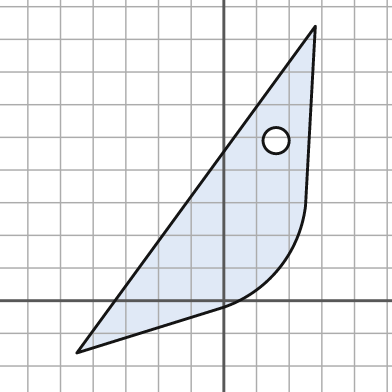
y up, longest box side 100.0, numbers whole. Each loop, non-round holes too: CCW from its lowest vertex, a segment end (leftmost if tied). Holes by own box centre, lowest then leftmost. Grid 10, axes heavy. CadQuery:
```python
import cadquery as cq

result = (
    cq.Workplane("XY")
    .moveTo(-45.0, -16.0)
    .lineTo(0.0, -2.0)
    .threePointArc((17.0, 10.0), (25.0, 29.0))
    .lineTo(28.0, 84.0)
    .close()
    .moveTo(16.0, 49.0)
    .circle(4.0)
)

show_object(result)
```